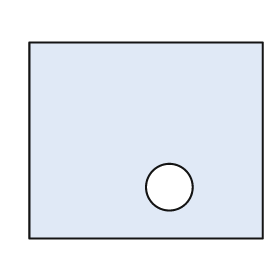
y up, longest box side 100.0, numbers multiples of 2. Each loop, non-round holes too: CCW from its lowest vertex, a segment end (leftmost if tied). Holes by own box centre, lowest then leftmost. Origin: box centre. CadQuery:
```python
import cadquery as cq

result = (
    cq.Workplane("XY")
    .moveTo(-50.0, -42.0)
    .lineTo(50.0, -42.0)
    .lineTo(50.0, 42.0)
    .lineTo(-50.0, 42.0)
    .close()
    .moveTo(10.0, -20.0)
    .circle(10.0)
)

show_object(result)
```